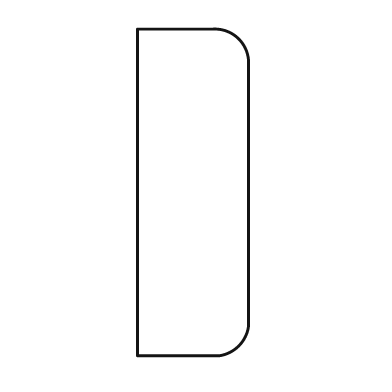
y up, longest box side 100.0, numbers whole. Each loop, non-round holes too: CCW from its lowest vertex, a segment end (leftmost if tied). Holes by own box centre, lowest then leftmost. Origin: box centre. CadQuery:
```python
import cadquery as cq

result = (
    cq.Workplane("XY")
    .moveTo(-17.0, -50.0)
    .lineTo(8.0, -50.0)
    .threePointArc((14.0, -47.0), (17.0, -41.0))
    .lineTo(17.0, 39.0)
    .threePointArc((14.0, 47.0), (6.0, 50.0))
    .lineTo(-17.0, 50.0)
    .close()
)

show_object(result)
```